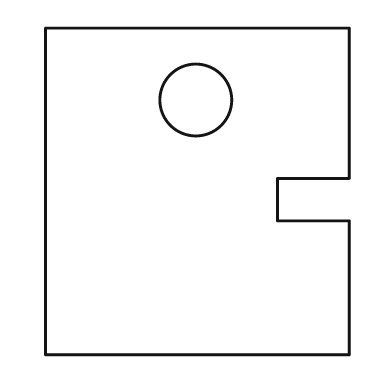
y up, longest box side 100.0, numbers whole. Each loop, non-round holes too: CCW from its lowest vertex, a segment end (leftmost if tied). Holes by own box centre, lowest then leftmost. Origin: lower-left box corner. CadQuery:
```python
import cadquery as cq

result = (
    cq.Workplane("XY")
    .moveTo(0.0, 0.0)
    .lineTo(93.0, 0.0)
    .lineTo(93.0, 41.0)
    .lineTo(71.0, 41.0)
    .lineTo(71.0, 54.0)
    .lineTo(93.0, 54.0)
    .lineTo(93.0, 100.0)
    .lineTo(0.0, 100.0)
    .close()
    .moveTo(46.0, 78.0)
    .circle(11.0)
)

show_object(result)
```